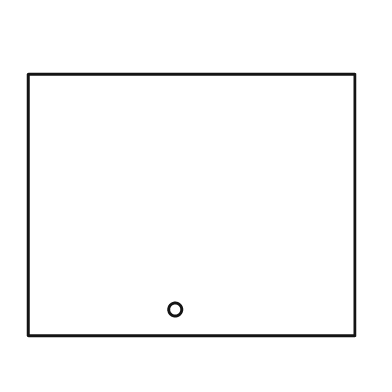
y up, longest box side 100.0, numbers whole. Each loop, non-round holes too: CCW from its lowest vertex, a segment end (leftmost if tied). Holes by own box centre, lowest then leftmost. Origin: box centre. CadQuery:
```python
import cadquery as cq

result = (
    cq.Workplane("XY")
    .moveTo(-50.0, -40.0)
    .lineTo(50.0, -40.0)
    .lineTo(50.0, 40.0)
    .lineTo(-50.0, 40.0)
    .close()
    .moveTo(-5.0, -32.0)
    .circle(2.0)
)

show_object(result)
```